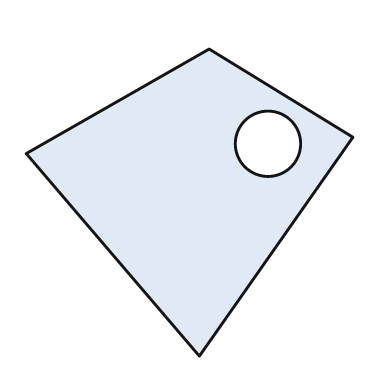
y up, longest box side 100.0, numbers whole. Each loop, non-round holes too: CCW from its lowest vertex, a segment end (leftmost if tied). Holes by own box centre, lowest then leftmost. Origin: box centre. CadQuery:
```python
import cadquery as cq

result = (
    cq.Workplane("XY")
    .moveTo(3.0, -47.0)
    .lineTo(50.0, 20.0)
    .lineTo(6.0, 47.0)
    .lineTo(-50.0, 15.0)
    .close()
    .moveTo(24.0, 18.0)
    .circle(10.0)
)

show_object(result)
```